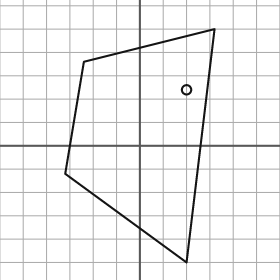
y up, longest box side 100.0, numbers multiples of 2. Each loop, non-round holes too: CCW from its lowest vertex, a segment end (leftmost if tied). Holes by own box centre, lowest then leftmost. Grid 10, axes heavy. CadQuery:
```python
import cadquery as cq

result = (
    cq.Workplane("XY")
    .moveTo(20.0, -50.0)
    .lineTo(32.0, 50.0)
    .lineTo(-24.0, 36.0)
    .lineTo(-32.0, -12.0)
    .close()
    .moveTo(20.0, 24.0)
    .circle(2.0)
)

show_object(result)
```